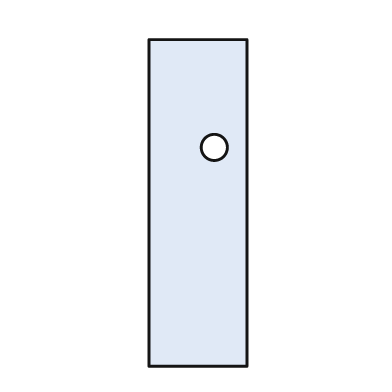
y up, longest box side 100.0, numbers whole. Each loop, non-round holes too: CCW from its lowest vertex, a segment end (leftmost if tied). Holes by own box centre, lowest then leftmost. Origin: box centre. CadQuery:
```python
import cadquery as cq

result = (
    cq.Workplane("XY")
    .moveTo(-15.0, -50.0)
    .lineTo(15.0, -50.0)
    .lineTo(15.0, 50.0)
    .lineTo(-15.0, 50.0)
    .close()
    .moveTo(5.0, 17.0)
    .circle(4.0)
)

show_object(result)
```